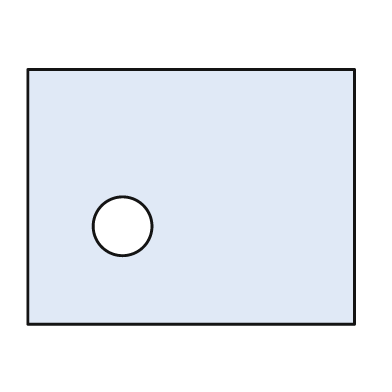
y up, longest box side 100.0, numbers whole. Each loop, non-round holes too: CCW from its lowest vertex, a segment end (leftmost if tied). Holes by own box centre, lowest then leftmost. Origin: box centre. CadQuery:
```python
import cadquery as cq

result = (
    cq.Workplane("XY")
    .moveTo(-50.0, -39.0)
    .lineTo(50.0, -39.0)
    .lineTo(50.0, 39.0)
    .lineTo(-50.0, 39.0)
    .close()
    .moveTo(-21.0, -9.0)
    .circle(9.0)
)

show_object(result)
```